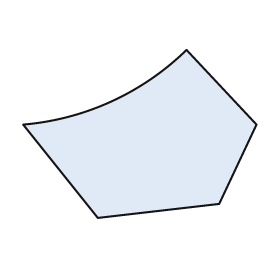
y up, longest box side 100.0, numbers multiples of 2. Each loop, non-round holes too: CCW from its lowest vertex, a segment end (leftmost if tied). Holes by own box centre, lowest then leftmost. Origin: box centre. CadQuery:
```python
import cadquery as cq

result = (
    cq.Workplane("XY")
    .moveTo(-18.0, -36.0)
    .lineTo(34.0, -30.0)
    .lineTo(50.0, 4.0)
    .lineTo(20.0, 36.0)
    .threePointArc((-12.0, 14.0), (-50.0, 4.0))
    .close()
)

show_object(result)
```